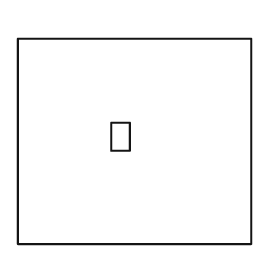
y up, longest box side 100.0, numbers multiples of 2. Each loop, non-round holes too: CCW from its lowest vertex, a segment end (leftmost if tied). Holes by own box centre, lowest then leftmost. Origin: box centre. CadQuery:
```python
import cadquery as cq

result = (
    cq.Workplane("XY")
    .moveTo(-50.0, -44.0)
    .lineTo(50.0, -44.0)
    .lineTo(50.0, 44.0)
    .lineTo(-50.0, 44.0)
    .close()
    .moveTo(-10.0, -4.0)
    .lineTo(-2.0, -4.0)
    .lineTo(-2.0, 8.0)
    .lineTo(-10.0, 8.0)
    .close()
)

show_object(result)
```